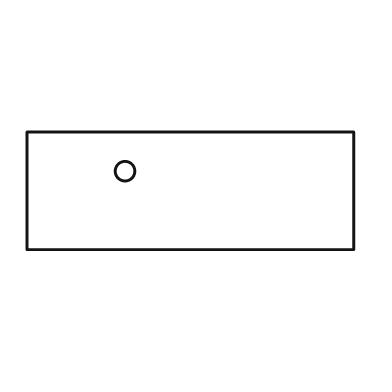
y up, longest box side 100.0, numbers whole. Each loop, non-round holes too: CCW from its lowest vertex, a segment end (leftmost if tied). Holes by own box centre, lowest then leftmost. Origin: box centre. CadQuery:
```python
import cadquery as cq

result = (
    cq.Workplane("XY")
    .moveTo(-50.0, -18.0)
    .lineTo(50.0, -18.0)
    .lineTo(50.0, 18.0)
    .lineTo(-50.0, 18.0)
    .close()
    .moveTo(-20.0, 6.0)
    .circle(3.0)
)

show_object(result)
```